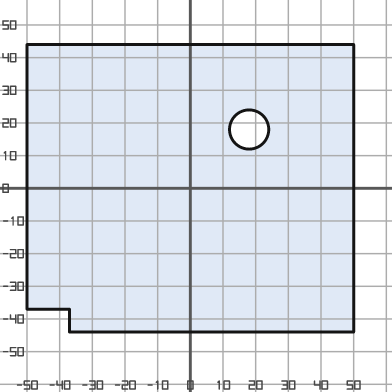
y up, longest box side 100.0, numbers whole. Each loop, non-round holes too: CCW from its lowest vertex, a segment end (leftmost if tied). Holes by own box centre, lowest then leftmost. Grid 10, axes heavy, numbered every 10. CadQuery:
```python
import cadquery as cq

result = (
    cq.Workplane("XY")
    .moveTo(-37.0, -44.0)
    .lineTo(50.0, -44.0)
    .lineTo(50.0, 44.0)
    .lineTo(-50.0, 44.0)
    .lineTo(-50.0, -37.0)
    .lineTo(-37.0, -37.0)
    .close()
    .moveTo(18.0, 18.0)
    .circle(6.0)
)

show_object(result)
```